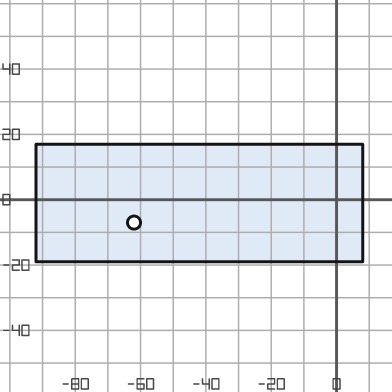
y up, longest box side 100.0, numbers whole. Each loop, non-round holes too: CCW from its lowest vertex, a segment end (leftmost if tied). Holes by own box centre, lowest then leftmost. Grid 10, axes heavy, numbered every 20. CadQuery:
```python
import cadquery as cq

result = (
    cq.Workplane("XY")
    .moveTo(-92.0, -19.0)
    .lineTo(8.0, -19.0)
    .lineTo(8.0, 17.0)
    .lineTo(-92.0, 17.0)
    .close()
    .moveTo(-62.0, -7.0)
    .circle(2.0)
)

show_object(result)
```